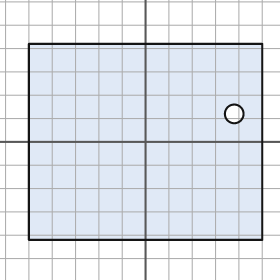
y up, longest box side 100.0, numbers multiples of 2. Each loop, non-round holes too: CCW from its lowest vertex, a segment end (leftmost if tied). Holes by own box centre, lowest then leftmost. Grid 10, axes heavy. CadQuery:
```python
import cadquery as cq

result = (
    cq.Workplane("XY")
    .moveTo(-50.0, -42.0)
    .lineTo(50.0, -42.0)
    .lineTo(50.0, 42.0)
    .lineTo(-50.0, 42.0)
    .close()
    .moveTo(38.0, 12.0)
    .circle(4.0)
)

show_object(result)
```